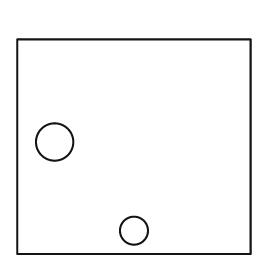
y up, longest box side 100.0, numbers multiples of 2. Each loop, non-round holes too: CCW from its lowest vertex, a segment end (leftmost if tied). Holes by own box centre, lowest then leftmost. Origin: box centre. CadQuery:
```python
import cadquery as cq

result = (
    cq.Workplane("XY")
    .moveTo(-50.0, -46.0)
    .lineTo(50.0, -46.0)
    .lineTo(50.0, 46.0)
    .lineTo(-50.0, 46.0)
    .close()
    .moveTo(0.0, -36.0)
    .circle(6.0)
    .moveTo(-34.0, 2.0)
    .circle(8.0)
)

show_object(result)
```